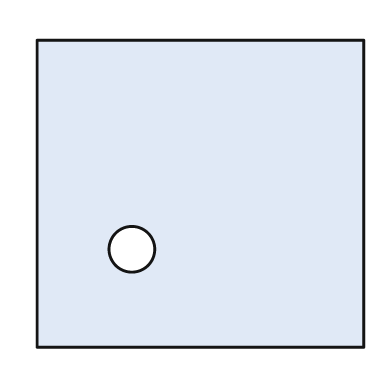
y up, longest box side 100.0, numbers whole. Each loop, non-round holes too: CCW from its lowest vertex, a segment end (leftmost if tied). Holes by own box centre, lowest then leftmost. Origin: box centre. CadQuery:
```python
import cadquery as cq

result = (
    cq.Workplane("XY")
    .moveTo(-50.0, -47.0)
    .lineTo(50.0, -47.0)
    .lineTo(50.0, 47.0)
    .lineTo(-50.0, 47.0)
    .close()
    .moveTo(-21.0, -17.0)
    .circle(7.0)
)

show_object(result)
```